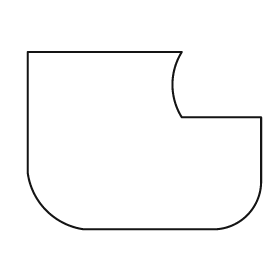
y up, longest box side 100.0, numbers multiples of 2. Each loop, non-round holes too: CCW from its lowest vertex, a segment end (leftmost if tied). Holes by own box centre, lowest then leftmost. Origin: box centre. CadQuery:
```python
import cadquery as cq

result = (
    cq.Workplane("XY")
    .moveTo(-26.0, -38.0)
    .lineTo(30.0, -38.0)
    .threePointArc((44.0, -32.0), (50.0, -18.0))
    .lineTo(50.0, 10.0)
    .lineTo(16.0, 10.0)
    .threePointArc((12.0, 24.0), (16.0, 38.0))
    .lineTo(-50.0, 38.0)
    .lineTo(-50.0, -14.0)
    .threePointArc((-42.0, -30.0), (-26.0, -38.0))
    .close()
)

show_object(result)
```